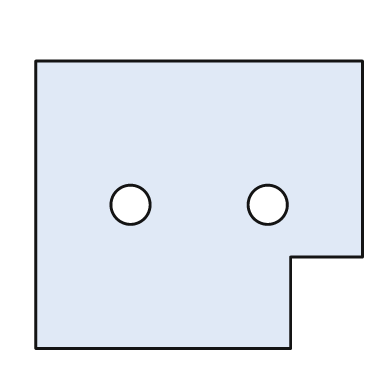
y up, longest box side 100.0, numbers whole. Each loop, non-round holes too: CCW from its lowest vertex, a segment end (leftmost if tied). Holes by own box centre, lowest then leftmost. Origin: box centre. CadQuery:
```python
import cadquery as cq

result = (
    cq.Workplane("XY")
    .moveTo(-50.0, -44.0)
    .lineTo(28.0, -44.0)
    .lineTo(28.0, -16.0)
    .lineTo(50.0, -16.0)
    .lineTo(50.0, 44.0)
    .lineTo(-50.0, 44.0)
    .close()
    .moveTo(-21.0, 0.0)
    .circle(6.0)
    .moveTo(21.0, 0.0)
    .circle(6.0)
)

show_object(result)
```